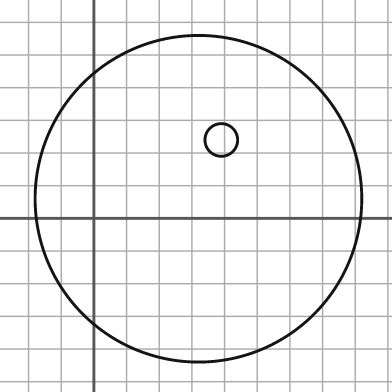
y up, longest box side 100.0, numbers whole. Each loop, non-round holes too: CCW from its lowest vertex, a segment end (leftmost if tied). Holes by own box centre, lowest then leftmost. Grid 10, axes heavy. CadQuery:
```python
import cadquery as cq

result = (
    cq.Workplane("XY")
    .moveTo(32.0, 6.0)
    .circle(50.0)
    .moveTo(39.0, 24.0)
    .circle(5.0)
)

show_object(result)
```